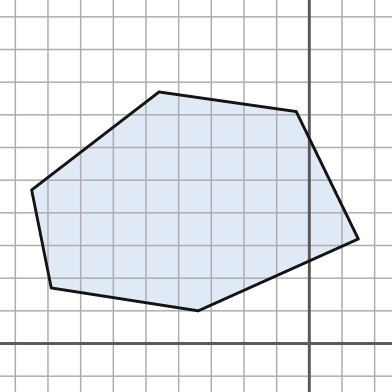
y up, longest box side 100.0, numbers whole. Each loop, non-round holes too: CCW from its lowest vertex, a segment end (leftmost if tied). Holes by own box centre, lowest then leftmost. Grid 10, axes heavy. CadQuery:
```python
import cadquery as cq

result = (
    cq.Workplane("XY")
    .moveTo(-34.0, 10.0)
    .lineTo(15.0, 32.0)
    .lineTo(-4.0, 71.0)
    .lineTo(-46.0, 77.0)
    .lineTo(-85.0, 47.0)
    .lineTo(-79.0, 17.0)
    .close()
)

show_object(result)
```